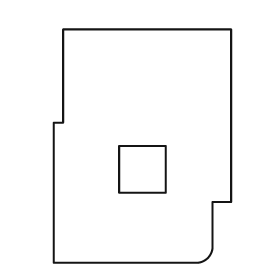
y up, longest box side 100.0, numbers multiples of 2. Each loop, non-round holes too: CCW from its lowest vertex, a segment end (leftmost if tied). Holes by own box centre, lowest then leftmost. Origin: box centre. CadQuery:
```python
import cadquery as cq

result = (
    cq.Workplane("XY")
    .moveTo(-38.0, -50.0)
    .lineTo(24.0, -50.0)
    .threePointArc((28.0, -48.0), (30.0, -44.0))
    .lineTo(30.0, -24.0)
    .lineTo(38.0, -24.0)
    .lineTo(38.0, 50.0)
    .lineTo(-34.0, 50.0)
    .lineTo(-34.0, 10.0)
    .lineTo(-38.0, 10.0)
    .close()
    .moveTo(-10.0, -20.0)
    .lineTo(10.0, -20.0)
    .lineTo(10.0, 0.0)
    .lineTo(-10.0, 0.0)
    .close()
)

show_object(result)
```